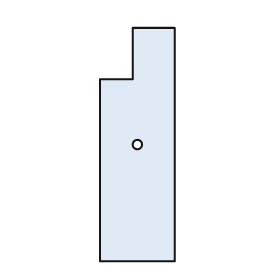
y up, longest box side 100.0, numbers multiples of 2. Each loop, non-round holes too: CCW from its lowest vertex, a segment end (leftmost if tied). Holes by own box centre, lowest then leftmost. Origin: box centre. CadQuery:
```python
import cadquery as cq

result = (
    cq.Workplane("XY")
    .moveTo(-16.0, -50.0)
    .lineTo(16.0, -50.0)
    .lineTo(16.0, 50.0)
    .lineTo(-2.0, 50.0)
    .lineTo(-2.0, 28.0)
    .lineTo(-16.0, 28.0)
    .close()
    .moveTo(0.0, 0.0)
    .circle(2.0)
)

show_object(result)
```